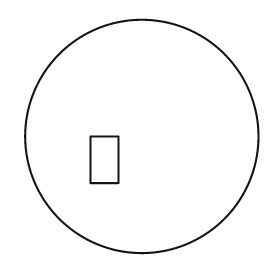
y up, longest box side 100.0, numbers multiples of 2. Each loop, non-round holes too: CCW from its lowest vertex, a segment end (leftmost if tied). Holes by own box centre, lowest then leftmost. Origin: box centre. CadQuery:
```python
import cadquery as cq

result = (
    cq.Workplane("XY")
    .moveTo(0.0, 0.0)
    .circle(50.0)
    .moveTo(-22.0, -20.0)
    .lineTo(-10.0, -20.0)
    .lineTo(-10.0, 0.0)
    .lineTo(-22.0, 0.0)
    .close()
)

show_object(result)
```